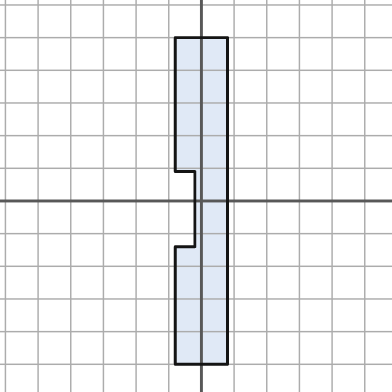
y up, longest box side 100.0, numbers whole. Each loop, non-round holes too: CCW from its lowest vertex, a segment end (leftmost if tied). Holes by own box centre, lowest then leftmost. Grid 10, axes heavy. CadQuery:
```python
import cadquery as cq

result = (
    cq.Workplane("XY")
    .moveTo(-8.0, -50.0)
    .lineTo(8.0, -50.0)
    .lineTo(8.0, 50.0)
    .lineTo(-8.0, 50.0)
    .lineTo(-8.0, 9.0)
    .lineTo(-2.0, 9.0)
    .lineTo(-2.0, -14.0)
    .lineTo(-8.0, -14.0)
    .close()
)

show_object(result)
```